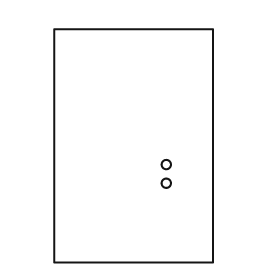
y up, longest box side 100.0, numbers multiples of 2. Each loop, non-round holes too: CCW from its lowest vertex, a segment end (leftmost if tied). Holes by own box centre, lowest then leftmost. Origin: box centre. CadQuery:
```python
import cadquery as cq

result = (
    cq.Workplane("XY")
    .moveTo(-34.0, -50.0)
    .lineTo(34.0, -50.0)
    .lineTo(34.0, 50.0)
    .lineTo(-34.0, 50.0)
    .close()
    .moveTo(14.0, -16.0)
    .circle(2.0)
    .moveTo(14.0, -8.0)
    .circle(2.0)
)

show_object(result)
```